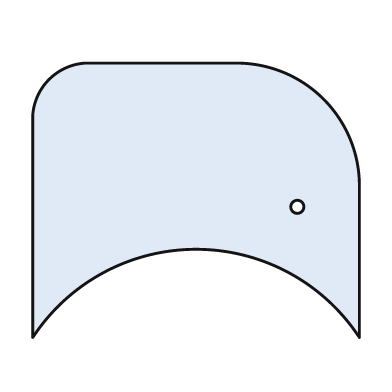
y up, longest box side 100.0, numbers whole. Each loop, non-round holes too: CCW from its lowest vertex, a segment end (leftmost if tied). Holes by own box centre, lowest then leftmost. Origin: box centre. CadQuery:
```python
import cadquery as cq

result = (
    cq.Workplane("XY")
    .moveTo(-50.0, -42.0)
    .threePointArc((0.0, -15.0), (50.0, -42.0))
    .lineTo(50.0, 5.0)
    .threePointArc((39.0, 31.0), (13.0, 42.0))
    .lineTo(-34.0, 42.0)
    .threePointArc((-45.0, 37.0), (-50.0, 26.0))
    .close()
    .moveTo(31.0, -2.0)
    .circle(2.0)
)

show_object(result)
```